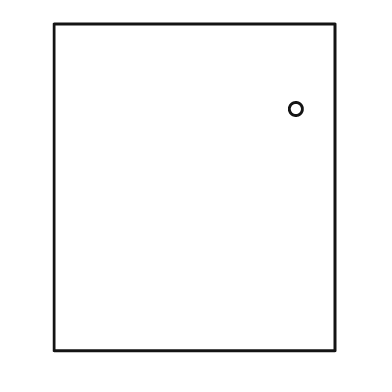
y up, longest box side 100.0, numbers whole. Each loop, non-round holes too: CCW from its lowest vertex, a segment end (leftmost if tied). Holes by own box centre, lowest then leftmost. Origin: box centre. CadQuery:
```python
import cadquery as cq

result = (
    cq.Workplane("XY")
    .moveTo(-43.0, -50.0)
    .lineTo(43.0, -50.0)
    .lineTo(43.0, 50.0)
    .lineTo(-43.0, 50.0)
    .close()
    .moveTo(31.0, 24.0)
    .circle(2.0)
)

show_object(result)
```